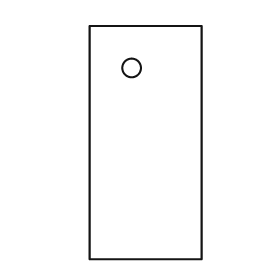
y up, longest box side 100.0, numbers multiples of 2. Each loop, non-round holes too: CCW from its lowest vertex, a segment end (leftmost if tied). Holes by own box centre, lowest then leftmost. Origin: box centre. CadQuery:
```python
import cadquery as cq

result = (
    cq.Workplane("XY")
    .moveTo(-24.0, -50.0)
    .lineTo(24.0, -50.0)
    .lineTo(24.0, 50.0)
    .lineTo(-24.0, 50.0)
    .close()
    .moveTo(-6.0, 32.0)
    .circle(4.0)
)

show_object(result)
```